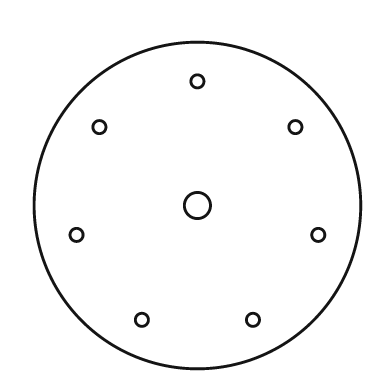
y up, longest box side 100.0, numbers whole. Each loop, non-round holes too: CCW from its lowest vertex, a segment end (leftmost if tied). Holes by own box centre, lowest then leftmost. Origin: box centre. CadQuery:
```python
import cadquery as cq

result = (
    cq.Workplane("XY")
    .moveTo(0.0, 0.0)
    .circle(50.0)
    .moveTo(-17.0, -35.0)
    .circle(2.0)
    .moveTo(17.0, -35.0)
    .circle(2.0)
    .moveTo(-37.0, -9.0)
    .circle(2.0)
    .moveTo(37.0, -9.0)
    .circle(2.0)
    .moveTo(0.0, 0.0)
    .circle(4.0)
    .moveTo(-30.0, 24.0)
    .circle(2.0)
    .moveTo(30.0, 24.0)
    .circle(2.0)
    .moveTo(0.0, 38.0)
    .circle(2.0)
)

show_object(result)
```